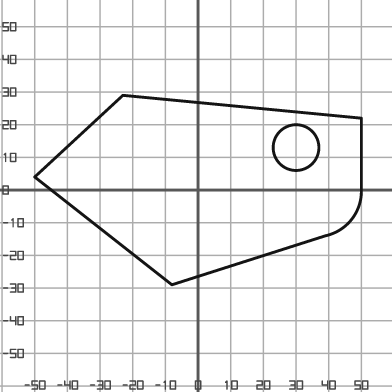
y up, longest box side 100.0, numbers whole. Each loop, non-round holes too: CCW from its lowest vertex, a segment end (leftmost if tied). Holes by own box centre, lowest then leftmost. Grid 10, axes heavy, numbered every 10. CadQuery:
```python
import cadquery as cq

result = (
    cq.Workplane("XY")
    .moveTo(-8.0, -29.0)
    .lineTo(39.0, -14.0)
    .threePointArc((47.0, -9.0), (50.0, 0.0))
    .lineTo(50.0, 22.0)
    .lineTo(-23.0, 29.0)
    .lineTo(-50.0, 4.0)
    .close()
    .moveTo(30.0, 13.0)
    .circle(7.0)
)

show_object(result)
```